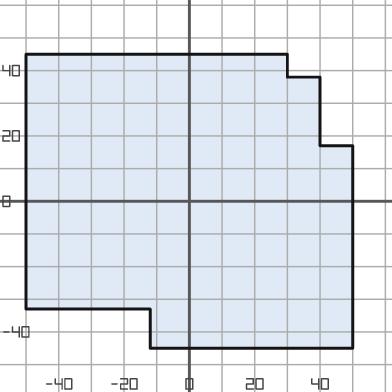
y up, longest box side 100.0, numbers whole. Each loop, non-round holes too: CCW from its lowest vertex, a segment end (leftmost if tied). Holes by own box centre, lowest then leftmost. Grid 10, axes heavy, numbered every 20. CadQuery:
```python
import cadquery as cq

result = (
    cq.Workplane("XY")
    .moveTo(-12.0, -45.0)
    .lineTo(50.0, -45.0)
    .lineTo(50.0, 17.0)
    .lineTo(40.0, 17.0)
    .lineTo(40.0, 38.0)
    .lineTo(30.0, 38.0)
    .lineTo(30.0, 45.0)
    .lineTo(-50.0, 45.0)
    .lineTo(-50.0, -33.0)
    .lineTo(-12.0, -33.0)
    .close()
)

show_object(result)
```